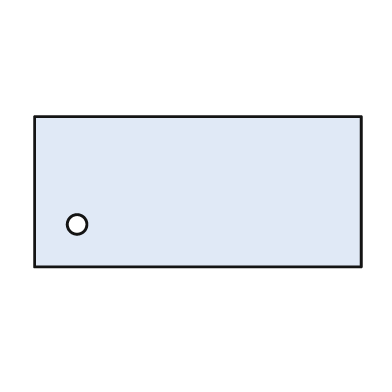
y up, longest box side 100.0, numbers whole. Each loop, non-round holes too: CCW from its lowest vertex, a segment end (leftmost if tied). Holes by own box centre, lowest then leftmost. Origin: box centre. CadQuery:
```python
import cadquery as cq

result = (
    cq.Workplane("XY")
    .moveTo(-50.0, -23.0)
    .lineTo(50.0, -23.0)
    .lineTo(50.0, 23.0)
    .lineTo(-50.0, 23.0)
    .close()
    .moveTo(-37.0, -10.0)
    .circle(3.0)
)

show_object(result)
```